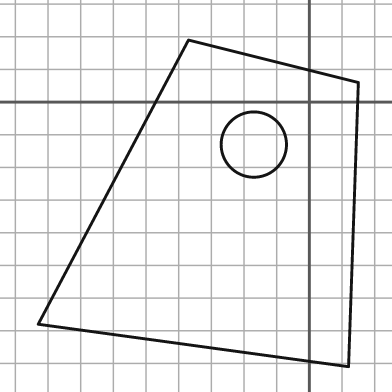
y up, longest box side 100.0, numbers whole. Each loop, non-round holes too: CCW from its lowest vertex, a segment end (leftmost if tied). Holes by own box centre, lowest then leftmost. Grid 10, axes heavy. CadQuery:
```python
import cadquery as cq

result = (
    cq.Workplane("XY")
    .moveTo(12.0, -81.0)
    .lineTo(15.0, 6.0)
    .lineTo(-37.0, 19.0)
    .lineTo(-83.0, -68.0)
    .close()
    .moveTo(-17.0, -13.0)
    .circle(10.0)
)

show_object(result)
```